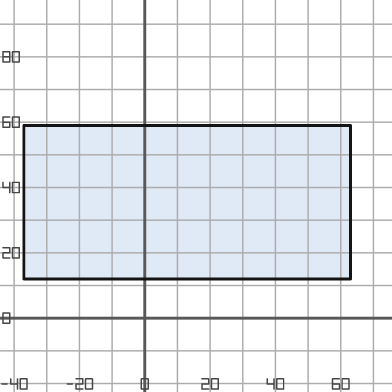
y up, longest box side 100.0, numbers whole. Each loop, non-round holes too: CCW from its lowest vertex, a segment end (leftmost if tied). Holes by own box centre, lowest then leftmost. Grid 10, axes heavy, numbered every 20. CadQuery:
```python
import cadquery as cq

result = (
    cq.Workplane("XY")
    .moveTo(-37.0, 12.0)
    .lineTo(63.0, 12.0)
    .lineTo(63.0, 59.0)
    .lineTo(-37.0, 59.0)
    .close()
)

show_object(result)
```